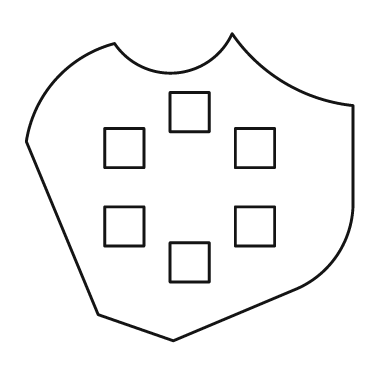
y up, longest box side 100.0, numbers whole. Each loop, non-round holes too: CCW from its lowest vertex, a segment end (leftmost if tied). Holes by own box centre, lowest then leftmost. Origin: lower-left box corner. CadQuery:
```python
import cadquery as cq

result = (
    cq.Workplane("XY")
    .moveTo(45.0, 0.0)
    .lineTo(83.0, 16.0)
    .threePointArc((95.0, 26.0), (100.0, 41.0))
    .lineTo(100.0, 72.0)
    .threePointArc((79.0, 79.0), (63.0, 94.0))
    .threePointArc((46.0, 82.0), (27.0, 91.0))
    .threePointArc((9.0, 80.0), (0.0, 61.0))
    .lineTo(22.0, 8.0)
    .close()
    .moveTo(44.0, 18.0)
    .lineTo(56.0, 18.0)
    .lineTo(56.0, 30.0)
    .lineTo(44.0, 30.0)
    .close()
    .moveTo(24.0, 29.0)
    .lineTo(36.0, 29.0)
    .lineTo(36.0, 41.0)
    .lineTo(24.0, 41.0)
    .close()
    .moveTo(64.0, 29.0)
    .lineTo(76.0, 29.0)
    .lineTo(76.0, 41.0)
    .lineTo(64.0, 41.0)
    .close()
    .moveTo(24.0, 53.0)
    .lineTo(36.0, 53.0)
    .lineTo(36.0, 65.0)
    .lineTo(24.0, 65.0)
    .close()
    .moveTo(64.0, 53.0)
    .lineTo(76.0, 53.0)
    .lineTo(76.0, 65.0)
    .lineTo(64.0, 65.0)
    .close()
    .moveTo(44.0, 64.0)
    .lineTo(56.0, 64.0)
    .lineTo(56.0, 76.0)
    .lineTo(44.0, 76.0)
    .close()
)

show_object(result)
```